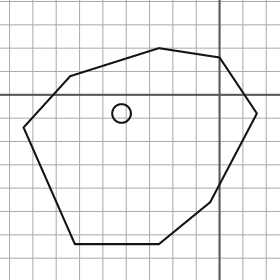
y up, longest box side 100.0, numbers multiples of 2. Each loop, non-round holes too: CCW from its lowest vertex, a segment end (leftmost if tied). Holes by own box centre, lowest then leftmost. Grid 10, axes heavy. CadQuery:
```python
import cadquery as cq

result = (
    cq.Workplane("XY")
    .moveTo(-62.0, -64.0)
    .lineTo(-26.0, -64.0)
    .lineTo(-4.0, -46.0)
    .lineTo(16.0, -8.0)
    .lineTo(0.0, 16.0)
    .lineTo(-26.0, 20.0)
    .lineTo(-64.0, 8.0)
    .lineTo(-84.0, -14.0)
    .close()
    .moveTo(-42.0, -8.0)
    .circle(4.0)
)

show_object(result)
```